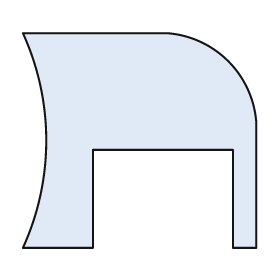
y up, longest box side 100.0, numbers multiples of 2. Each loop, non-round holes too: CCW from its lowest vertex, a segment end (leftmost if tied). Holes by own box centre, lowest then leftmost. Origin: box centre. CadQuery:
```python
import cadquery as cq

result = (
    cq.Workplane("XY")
    .moveTo(-50.0, -46.0)
    .lineTo(-20.0, -46.0)
    .lineTo(-20.0, -4.0)
    .lineTo(40.0, -4.0)
    .lineTo(40.0, -46.0)
    .lineTo(50.0, -46.0)
    .lineTo(50.0, 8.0)
    .threePointArc((38.0, 34.0), (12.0, 46.0))
    .lineTo(-50.0, 46.0)
    .threePointArc((-40.0, 0.0), (-50.0, -46.0))
    .close()
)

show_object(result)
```